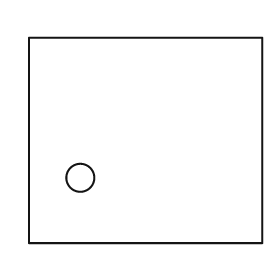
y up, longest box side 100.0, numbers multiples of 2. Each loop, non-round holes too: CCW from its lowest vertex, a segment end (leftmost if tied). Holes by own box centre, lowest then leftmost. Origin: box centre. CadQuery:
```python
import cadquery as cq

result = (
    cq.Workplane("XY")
    .moveTo(-50.0, -44.0)
    .lineTo(50.0, -44.0)
    .lineTo(50.0, 44.0)
    .lineTo(-50.0, 44.0)
    .close()
    .moveTo(-28.0, -16.0)
    .circle(6.0)
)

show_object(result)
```